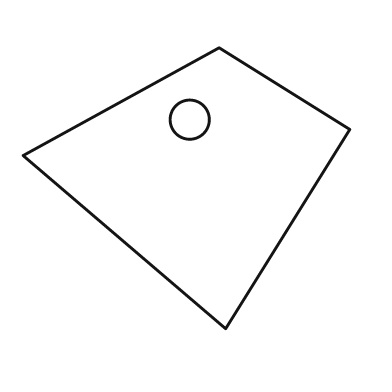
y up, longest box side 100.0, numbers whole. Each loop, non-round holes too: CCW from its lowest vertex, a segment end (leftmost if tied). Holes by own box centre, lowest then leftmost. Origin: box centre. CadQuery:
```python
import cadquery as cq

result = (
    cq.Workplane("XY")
    .moveTo(12.0, -43.0)
    .lineTo(50.0, 18.0)
    .lineTo(10.0, 43.0)
    .lineTo(-50.0, 10.0)
    .close()
    .moveTo(1.0, 21.0)
    .circle(6.0)
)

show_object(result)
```